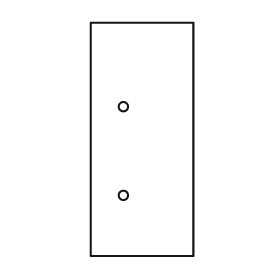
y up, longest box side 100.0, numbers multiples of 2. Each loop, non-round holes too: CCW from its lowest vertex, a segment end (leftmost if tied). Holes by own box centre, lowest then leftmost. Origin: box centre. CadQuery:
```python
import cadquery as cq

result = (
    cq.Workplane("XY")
    .moveTo(-22.0, -50.0)
    .lineTo(22.0, -50.0)
    .lineTo(22.0, 50.0)
    .lineTo(-22.0, 50.0)
    .close()
    .moveTo(-8.0, -24.0)
    .circle(2.0)
    .moveTo(-8.0, 14.0)
    .circle(2.0)
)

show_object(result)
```